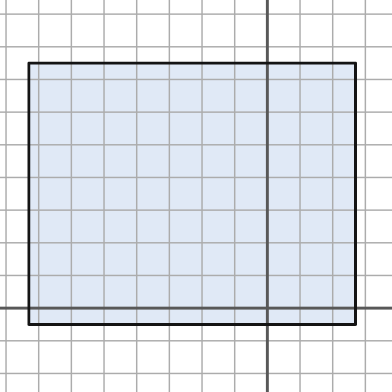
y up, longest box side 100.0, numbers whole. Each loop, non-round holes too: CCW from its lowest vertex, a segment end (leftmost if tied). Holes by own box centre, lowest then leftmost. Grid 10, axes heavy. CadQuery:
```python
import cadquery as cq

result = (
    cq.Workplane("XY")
    .moveTo(-73.0, -5.0)
    .lineTo(27.0, -5.0)
    .lineTo(27.0, 75.0)
    .lineTo(-73.0, 75.0)
    .close()
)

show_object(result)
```